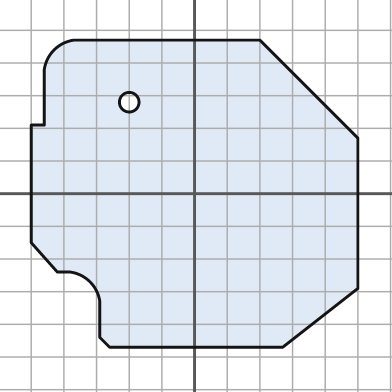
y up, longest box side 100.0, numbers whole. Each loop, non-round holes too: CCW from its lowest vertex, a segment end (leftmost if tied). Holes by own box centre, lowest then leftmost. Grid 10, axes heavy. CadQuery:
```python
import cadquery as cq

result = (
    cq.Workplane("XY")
    .moveTo(-26.0, -47.0)
    .lineTo(27.0, -47.0)
    .lineTo(50.0, -29.0)
    .lineTo(50.0, 17.0)
    .lineTo(20.0, 47.0)
    .lineTo(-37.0, 47.0)
    .threePointArc((-43.0, 44.0), (-46.0, 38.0))
    .lineTo(-46.0, 21.0)
    .lineTo(-50.0, 21.0)
    .lineTo(-50.0, -15.0)
    .lineTo(-42.0, -24.0)
    .lineTo(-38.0, -24.0)
    .threePointArc((-32.0, -27.0), (-29.0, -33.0))
    .lineTo(-29.0, -44.0)
    .close()
    .moveTo(-20.0, 28.0)
    .circle(3.0)
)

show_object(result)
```